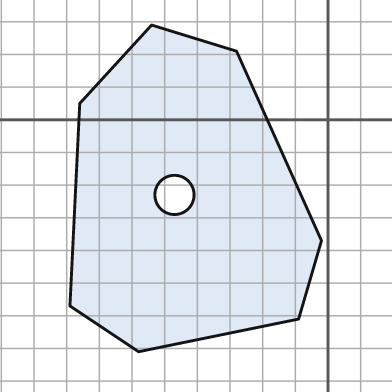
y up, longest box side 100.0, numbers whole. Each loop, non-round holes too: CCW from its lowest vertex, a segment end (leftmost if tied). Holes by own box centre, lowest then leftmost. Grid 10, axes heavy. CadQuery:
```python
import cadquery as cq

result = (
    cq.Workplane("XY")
    .moveTo(-58.0, -71.0)
    .lineTo(-9.0, -61.0)
    .lineTo(-2.0, -37.0)
    .lineTo(-28.0, 21.0)
    .lineTo(-54.0, 29.0)
    .lineTo(-76.0, 5.0)
    .lineTo(-79.0, -57.0)
    .close()
    .moveTo(-47.0, -23.0)
    .circle(6.0)
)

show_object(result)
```